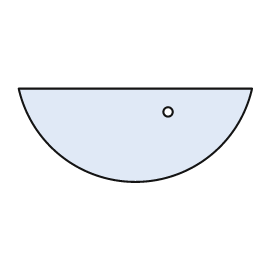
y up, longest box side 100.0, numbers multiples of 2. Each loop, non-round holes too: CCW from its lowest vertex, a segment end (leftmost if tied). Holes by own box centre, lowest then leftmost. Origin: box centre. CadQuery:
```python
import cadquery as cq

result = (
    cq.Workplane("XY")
    .moveTo(-50.0, 20.0)
    .threePointArc((0.0, -20.0), (50.0, 20.0))
    .close()
    .moveTo(14.0, 10.0)
    .circle(2.0)
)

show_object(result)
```